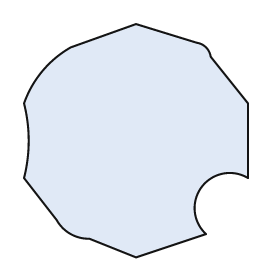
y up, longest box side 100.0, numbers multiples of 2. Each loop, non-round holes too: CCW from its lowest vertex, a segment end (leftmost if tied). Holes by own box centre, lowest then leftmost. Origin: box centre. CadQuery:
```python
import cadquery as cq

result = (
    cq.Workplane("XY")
    .moveTo(0.0, -50.0)
    .lineTo(30.0, -40.0)
    .threePointArc((28.0, -20.0), (48.0, -16.0))
    .lineTo(48.0, 16.0)
    .lineTo(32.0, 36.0)
    .threePointArc((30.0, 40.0), (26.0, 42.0))
    .lineTo(0.0, 50.0)
    .lineTo(-28.0, 40.0)
    .threePointArc((-40.0, 30.0), (-48.0, 16.0))
    .threePointArc((-46.0, 0.0), (-48.0, -16.0))
    .lineTo(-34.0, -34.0)
    .threePointArc((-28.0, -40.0), (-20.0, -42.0))
    .close()
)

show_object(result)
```